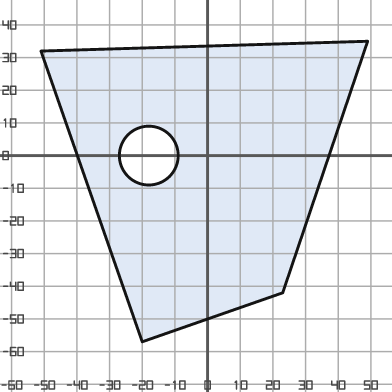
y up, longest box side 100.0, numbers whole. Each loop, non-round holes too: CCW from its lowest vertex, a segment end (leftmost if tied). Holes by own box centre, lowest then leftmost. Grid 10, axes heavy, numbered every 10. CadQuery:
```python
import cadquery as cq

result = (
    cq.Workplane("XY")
    .moveTo(-20.0, -57.0)
    .lineTo(23.0, -42.0)
    .lineTo(49.0, 35.0)
    .lineTo(-51.0, 32.0)
    .close()
    .moveTo(-18.0, 0.0)
    .circle(9.0)
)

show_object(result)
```